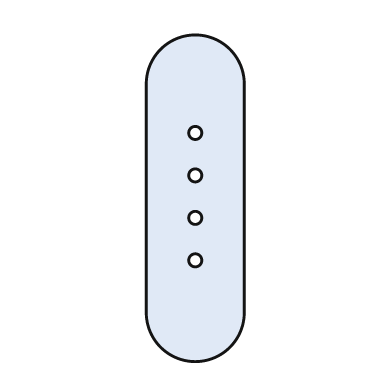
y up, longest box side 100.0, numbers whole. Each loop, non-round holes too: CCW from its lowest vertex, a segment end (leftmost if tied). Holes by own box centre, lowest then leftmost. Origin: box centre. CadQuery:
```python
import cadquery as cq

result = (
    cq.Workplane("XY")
    .moveTo(-15.0, -35.0)
    .threePointArc((0.0, -50.0), (15.0, -35.0))
    .lineTo(15.0, 35.0)
    .threePointArc((0.0, 50.0), (-15.0, 35.0))
    .close()
    .moveTo(0.0, -19.0)
    .circle(2.0)
    .moveTo(0.0, -6.0)
    .circle(2.0)
    .moveTo(0.0, 7.0)
    .circle(2.0)
    .moveTo(0.0, 20.0)
    .circle(2.0)
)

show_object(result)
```